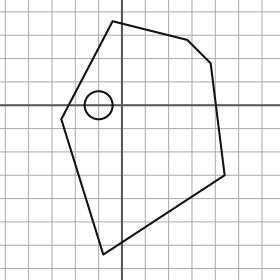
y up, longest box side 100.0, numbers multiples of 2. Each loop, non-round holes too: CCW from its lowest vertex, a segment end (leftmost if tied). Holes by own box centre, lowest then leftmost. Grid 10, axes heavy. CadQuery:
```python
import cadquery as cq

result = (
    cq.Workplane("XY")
    .moveTo(-8.0, -64.0)
    .lineTo(44.0, -30.0)
    .lineTo(38.0, 18.0)
    .lineTo(28.0, 28.0)
    .lineTo(-4.0, 36.0)
    .lineTo(-26.0, -6.0)
    .close()
    .moveTo(-10.0, 0.0)
    .circle(6.0)
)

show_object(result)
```